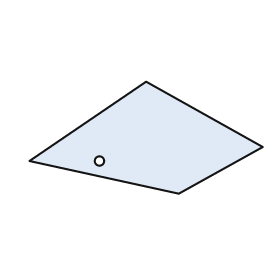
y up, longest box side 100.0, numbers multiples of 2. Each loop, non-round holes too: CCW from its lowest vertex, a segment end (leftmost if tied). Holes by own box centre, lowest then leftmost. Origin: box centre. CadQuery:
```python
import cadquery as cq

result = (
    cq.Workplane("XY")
    .moveTo(14.0, -24.0)
    .lineTo(50.0, -4.0)
    .lineTo(0.0, 24.0)
    .lineTo(-50.0, -10.0)
    .close()
    .moveTo(-20.0, -10.0)
    .circle(2.0)
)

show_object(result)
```